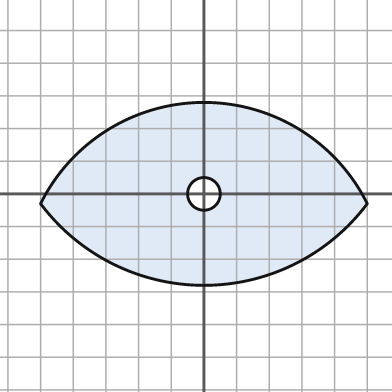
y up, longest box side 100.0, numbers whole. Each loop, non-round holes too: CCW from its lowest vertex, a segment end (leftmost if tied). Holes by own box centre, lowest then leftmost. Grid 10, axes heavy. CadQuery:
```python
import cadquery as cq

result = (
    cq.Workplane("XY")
    .moveTo(-50.0, -3.0)
    .threePointArc((0.0, -28.0), (50.0, -3.0))
    .threePointArc((0.0, 28.0), (-50.0, -3.0))
    .close()
    .moveTo(0.0, 0.0)
    .circle(5.0)
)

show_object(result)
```